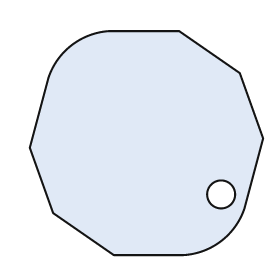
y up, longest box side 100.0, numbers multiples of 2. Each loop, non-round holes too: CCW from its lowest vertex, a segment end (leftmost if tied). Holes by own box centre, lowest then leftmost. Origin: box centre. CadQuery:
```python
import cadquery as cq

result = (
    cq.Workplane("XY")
    .moveTo(-14.0, -48.0)
    .lineTo(16.0, -48.0)
    .threePointArc((32.0, -42.0), (42.0, -28.0))
    .lineTo(50.0, 2.0)
    .lineTo(40.0, 30.0)
    .lineTo(14.0, 48.0)
    .lineTo(-16.0, 48.0)
    .threePointArc((-32.0, 42.0), (-42.0, 28.0))
    .lineTo(-50.0, -2.0)
    .lineTo(-40.0, -30.0)
    .close()
    .moveTo(32.0, -22.0)
    .circle(6.0)
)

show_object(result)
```